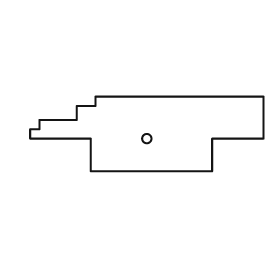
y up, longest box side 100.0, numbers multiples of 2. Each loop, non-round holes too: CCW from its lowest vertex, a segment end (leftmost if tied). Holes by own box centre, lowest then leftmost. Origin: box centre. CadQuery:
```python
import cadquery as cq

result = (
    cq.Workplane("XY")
    .moveTo(-24.0, -16.0)
    .lineTo(28.0, -16.0)
    .lineTo(28.0, -2.0)
    .lineTo(50.0, -2.0)
    .lineTo(50.0, 16.0)
    .lineTo(-22.0, 16.0)
    .lineTo(-22.0, 12.0)
    .lineTo(-30.0, 12.0)
    .lineTo(-30.0, 6.0)
    .lineTo(-46.0, 6.0)
    .lineTo(-46.0, 2.0)
    .lineTo(-50.0, 2.0)
    .lineTo(-50.0, -2.0)
    .lineTo(-24.0, -2.0)
    .close()
    .moveTo(0.0, -2.0)
    .circle(2.0)
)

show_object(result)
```